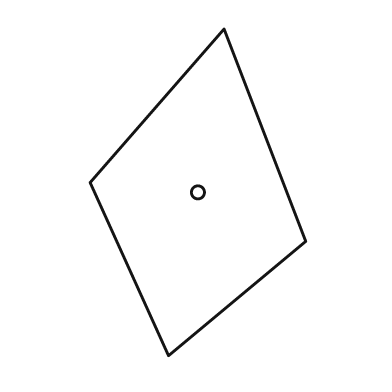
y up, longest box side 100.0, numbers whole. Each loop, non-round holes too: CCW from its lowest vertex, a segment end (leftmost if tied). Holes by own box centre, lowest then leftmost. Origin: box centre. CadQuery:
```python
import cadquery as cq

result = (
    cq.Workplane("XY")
    .moveTo(-9.0, -50.0)
    .lineTo(33.0, -15.0)
    .lineTo(8.0, 50.0)
    .lineTo(-33.0, 3.0)
    .close()
    .moveTo(0.0, 0.0)
    .circle(2.0)
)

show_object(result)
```